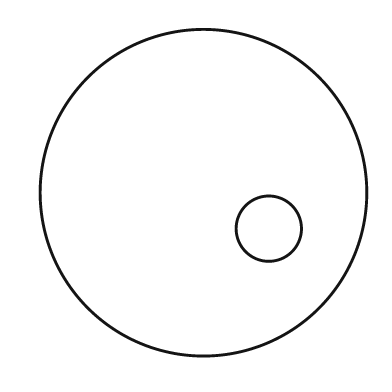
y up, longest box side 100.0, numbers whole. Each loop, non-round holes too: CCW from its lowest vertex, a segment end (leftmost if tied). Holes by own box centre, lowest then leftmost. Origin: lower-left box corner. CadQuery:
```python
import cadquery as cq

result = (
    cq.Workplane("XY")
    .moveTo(50.0, 50.0)
    .circle(50.0)
    .moveTo(70.0, 39.0)
    .circle(10.0)
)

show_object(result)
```